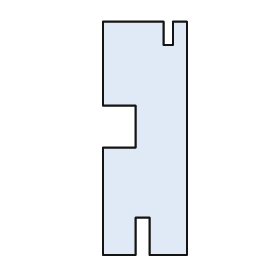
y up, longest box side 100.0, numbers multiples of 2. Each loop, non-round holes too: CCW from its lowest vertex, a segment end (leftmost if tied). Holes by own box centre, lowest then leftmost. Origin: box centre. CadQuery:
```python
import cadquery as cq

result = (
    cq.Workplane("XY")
    .moveTo(-18.0, -50.0)
    .lineTo(-4.0, -50.0)
    .lineTo(-4.0, -34.0)
    .lineTo(2.0, -34.0)
    .lineTo(2.0, -50.0)
    .lineTo(18.0, -50.0)
    .lineTo(18.0, 50.0)
    .lineTo(12.0, 50.0)
    .lineTo(12.0, 40.0)
    .lineTo(8.0, 40.0)
    .lineTo(8.0, 50.0)
    .lineTo(-18.0, 50.0)
    .lineTo(-18.0, 14.0)
    .lineTo(-4.0, 14.0)
    .lineTo(-4.0, -4.0)
    .lineTo(-18.0, -4.0)
    .close()
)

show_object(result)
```